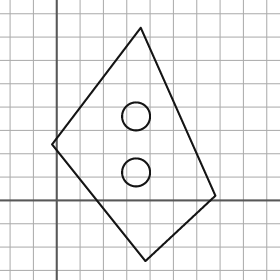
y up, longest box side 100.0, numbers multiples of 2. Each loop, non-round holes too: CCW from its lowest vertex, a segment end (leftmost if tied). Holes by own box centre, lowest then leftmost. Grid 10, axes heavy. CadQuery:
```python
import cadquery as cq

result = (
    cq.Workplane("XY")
    .moveTo(38.0, -26.0)
    .lineTo(68.0, 2.0)
    .lineTo(36.0, 74.0)
    .lineTo(-2.0, 24.0)
    .close()
    .moveTo(34.0, 12.0)
    .circle(6.0)
    .moveTo(34.0, 36.0)
    .circle(6.0)
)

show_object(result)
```